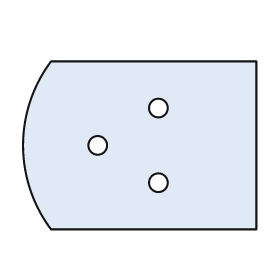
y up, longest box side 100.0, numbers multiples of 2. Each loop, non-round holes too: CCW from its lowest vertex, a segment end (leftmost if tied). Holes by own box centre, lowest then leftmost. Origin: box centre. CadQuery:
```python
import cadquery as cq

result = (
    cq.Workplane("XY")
    .moveTo(-38.0, -36.0)
    .lineTo(50.0, -36.0)
    .lineTo(50.0, 36.0)
    .lineTo(-38.0, 36.0)
    .threePointArc((-50.0, 0.0), (-38.0, -36.0))
    .close()
    .moveTo(8.0, -16.0)
    .circle(4.0)
    .moveTo(-18.0, 0.0)
    .circle(4.0)
    .moveTo(8.0, 16.0)
    .circle(4.0)
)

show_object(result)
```